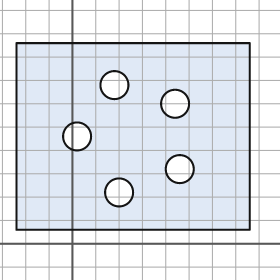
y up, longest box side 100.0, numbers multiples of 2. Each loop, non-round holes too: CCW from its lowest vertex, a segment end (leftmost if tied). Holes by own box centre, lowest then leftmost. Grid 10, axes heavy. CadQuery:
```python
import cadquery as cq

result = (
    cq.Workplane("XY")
    .moveTo(-24.0, 6.0)
    .lineTo(76.0, 6.0)
    .lineTo(76.0, 86.0)
    .lineTo(-24.0, 86.0)
    .close()
    .moveTo(20.0, 22.0)
    .circle(6.0)
    .moveTo(46.0, 32.0)
    .circle(6.0)
    .moveTo(2.0, 46.0)
    .circle(6.0)
    .moveTo(44.0, 60.0)
    .circle(6.0)
    .moveTo(18.0, 68.0)
    .circle(6.0)
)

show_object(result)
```